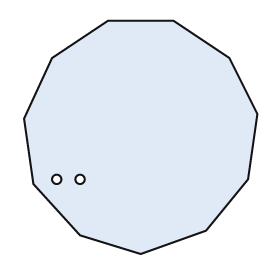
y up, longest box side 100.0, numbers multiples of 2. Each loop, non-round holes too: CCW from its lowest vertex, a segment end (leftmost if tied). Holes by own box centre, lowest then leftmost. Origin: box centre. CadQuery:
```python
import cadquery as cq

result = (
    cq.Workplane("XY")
    .moveTo(0.0, -50.0)
    .lineTo(28.0, -40.0)
    .lineTo(46.0, -18.0)
    .lineTo(50.0, 10.0)
    .lineTo(38.0, 34.0)
    .lineTo(14.0, 50.0)
    .lineTo(-14.0, 50.0)
    .lineTo(-38.0, 34.0)
    .lineTo(-50.0, 8.0)
    .lineTo(-46.0, -20.0)
    .lineTo(-26.0, -42.0)
    .close()
    .moveTo(-36.0, -18.0)
    .circle(2.0)
    .moveTo(-26.0, -18.0)
    .circle(2.0)
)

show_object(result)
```